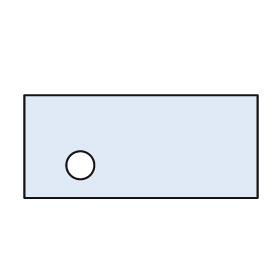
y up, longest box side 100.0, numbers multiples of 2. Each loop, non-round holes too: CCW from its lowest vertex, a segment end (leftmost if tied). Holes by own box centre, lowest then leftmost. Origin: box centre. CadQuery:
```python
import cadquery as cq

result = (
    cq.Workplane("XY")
    .moveTo(-50.0, -22.0)
    .lineTo(50.0, -22.0)
    .lineTo(50.0, 22.0)
    .lineTo(-50.0, 22.0)
    .close()
    .moveTo(-26.0, -8.0)
    .circle(6.0)
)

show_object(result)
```